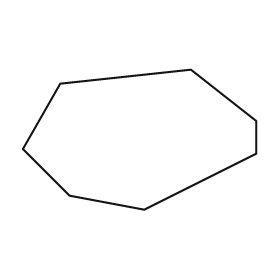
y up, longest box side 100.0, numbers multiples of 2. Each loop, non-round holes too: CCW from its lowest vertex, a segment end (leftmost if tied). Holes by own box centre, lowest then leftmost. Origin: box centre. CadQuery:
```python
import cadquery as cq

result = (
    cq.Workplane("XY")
    .moveTo(2.0, -30.0)
    .lineTo(50.0, -6.0)
    .lineTo(50.0, 8.0)
    .lineTo(22.0, 30.0)
    .lineTo(-34.0, 24.0)
    .lineTo(-50.0, -4.0)
    .lineTo(-30.0, -24.0)
    .close()
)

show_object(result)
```